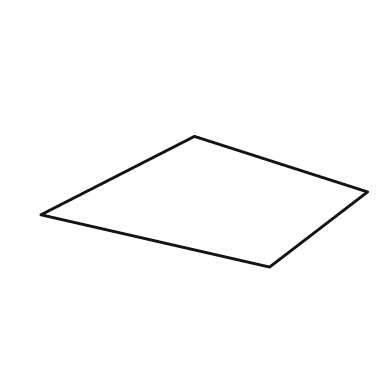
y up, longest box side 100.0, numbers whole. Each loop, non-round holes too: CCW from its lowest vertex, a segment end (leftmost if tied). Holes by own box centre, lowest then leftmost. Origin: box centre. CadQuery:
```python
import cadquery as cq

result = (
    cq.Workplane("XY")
    .moveTo(20.0, -20.0)
    .lineTo(50.0, 3.0)
    .lineTo(-3.0, 20.0)
    .lineTo(-50.0, -4.0)
    .close()
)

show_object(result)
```